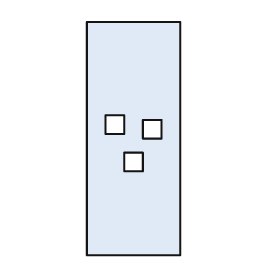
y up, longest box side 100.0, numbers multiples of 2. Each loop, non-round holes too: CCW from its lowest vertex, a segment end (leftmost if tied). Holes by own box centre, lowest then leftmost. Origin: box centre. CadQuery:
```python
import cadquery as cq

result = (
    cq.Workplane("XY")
    .moveTo(-20.0, -50.0)
    .lineTo(20.0, -50.0)
    .lineTo(20.0, 50.0)
    .lineTo(-20.0, 50.0)
    .close()
    .moveTo(-4.0, -14.0)
    .lineTo(4.0, -14.0)
    .lineTo(4.0, -6.0)
    .lineTo(-4.0, -6.0)
    .close()
    .moveTo(4.0, 0.0)
    .lineTo(12.0, 0.0)
    .lineTo(12.0, 8.0)
    .lineTo(4.0, 8.0)
    .close()
    .moveTo(-12.0, 2.0)
    .lineTo(-4.0, 2.0)
    .lineTo(-4.0, 10.0)
    .lineTo(-12.0, 10.0)
    .close()
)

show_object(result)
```